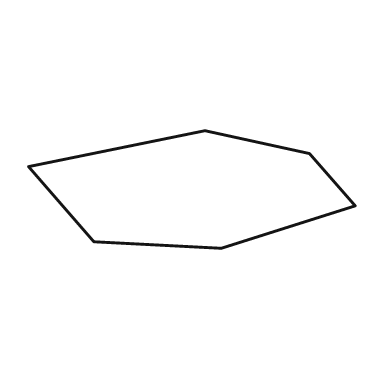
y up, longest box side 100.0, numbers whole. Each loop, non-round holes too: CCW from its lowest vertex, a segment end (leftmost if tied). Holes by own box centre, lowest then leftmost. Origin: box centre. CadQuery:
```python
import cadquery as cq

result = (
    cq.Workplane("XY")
    .moveTo(9.0, -18.0)
    .lineTo(50.0, -5.0)
    .lineTo(36.0, 11.0)
    .lineTo(4.0, 18.0)
    .lineTo(-50.0, 7.0)
    .lineTo(-30.0, -16.0)
    .close()
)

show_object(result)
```